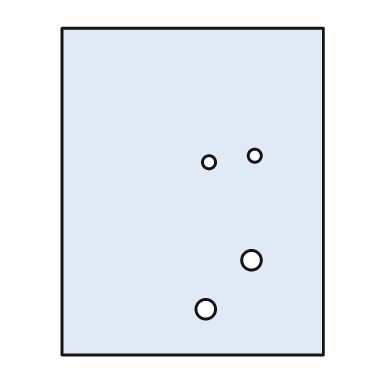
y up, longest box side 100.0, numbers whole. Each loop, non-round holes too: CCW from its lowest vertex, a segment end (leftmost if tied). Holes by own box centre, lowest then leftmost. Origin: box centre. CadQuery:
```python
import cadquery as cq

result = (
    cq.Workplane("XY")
    .moveTo(-40.0, -50.0)
    .lineTo(40.0, -50.0)
    .lineTo(40.0, 50.0)
    .lineTo(-40.0, 50.0)
    .close()
    .moveTo(4.0, -36.0)
    .circle(3.0)
    .moveTo(18.0, -21.0)
    .circle(3.0)
    .moveTo(5.0, 9.0)
    .circle(2.0)
    .moveTo(19.0, 11.0)
    .circle(2.0)
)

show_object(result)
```